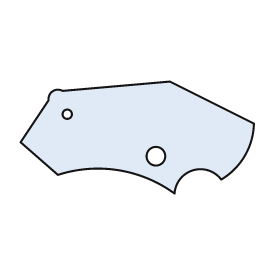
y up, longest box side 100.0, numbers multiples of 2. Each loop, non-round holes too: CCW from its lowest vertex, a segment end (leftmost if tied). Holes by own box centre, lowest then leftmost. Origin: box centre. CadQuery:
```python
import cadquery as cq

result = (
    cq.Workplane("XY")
    .moveTo(16.0, -24.0)
    .threePointArc((24.0, -14.0), (36.0, -18.0))
    .threePointArc((46.0, -8.0), (50.0, 6.0))
    .lineTo(14.0, 24.0)
    .lineTo(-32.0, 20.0)
    .threePointArc((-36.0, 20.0), (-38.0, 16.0))
    .lineTo(-50.0, -2.0)
    .lineTo(-34.0, -16.0)
    .threePointArc((-8.0, -14.0), (16.0, -24.0))
    .close()
    .moveTo(8.0, -8.0)
    .circle(4.0)
    .moveTo(-30.0, 10.0)
    .circle(2.0)
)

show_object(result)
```